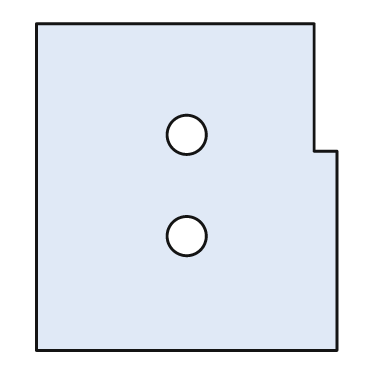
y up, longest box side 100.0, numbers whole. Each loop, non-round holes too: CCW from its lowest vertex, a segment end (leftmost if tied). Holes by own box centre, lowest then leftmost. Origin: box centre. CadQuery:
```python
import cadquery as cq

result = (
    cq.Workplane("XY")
    .moveTo(-46.0, -50.0)
    .lineTo(46.0, -50.0)
    .lineTo(46.0, 11.0)
    .lineTo(39.0, 11.0)
    .lineTo(39.0, 50.0)
    .lineTo(-46.0, 50.0)
    .close()
    .moveTo(0.0, -15.0)
    .circle(6.0)
    .moveTo(0.0, 16.0)
    .circle(6.0)
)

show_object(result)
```